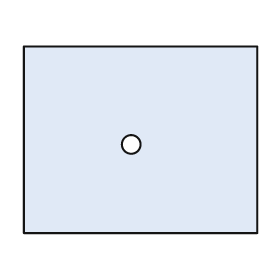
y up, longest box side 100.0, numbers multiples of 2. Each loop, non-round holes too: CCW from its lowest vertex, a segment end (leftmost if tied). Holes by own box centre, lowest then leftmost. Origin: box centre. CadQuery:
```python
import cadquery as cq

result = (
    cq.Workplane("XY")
    .moveTo(-50.0, -40.0)
    .lineTo(50.0, -40.0)
    .lineTo(50.0, 40.0)
    .lineTo(-50.0, 40.0)
    .close()
    .moveTo(-4.0, -2.0)
    .circle(4.0)
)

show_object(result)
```